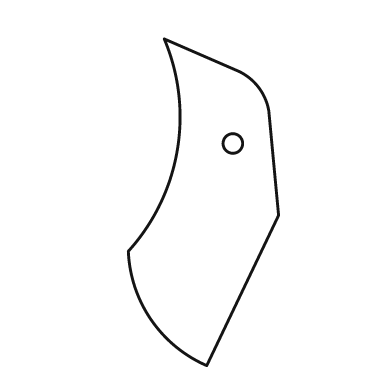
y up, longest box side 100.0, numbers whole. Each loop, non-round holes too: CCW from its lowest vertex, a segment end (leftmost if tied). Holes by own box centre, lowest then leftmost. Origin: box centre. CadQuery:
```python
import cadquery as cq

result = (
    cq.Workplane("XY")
    .moveTo(1.0, -50.0)
    .lineTo(23.0, -4.0)
    .lineTo(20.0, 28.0)
    .threePointArc((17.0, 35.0), (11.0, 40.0))
    .lineTo(-12.0, 50.0)
    .threePointArc((-8.0, 16.0), (-23.0, -15.0))
    .threePointArc((-16.0, -36.0), (1.0, -50.0))
    .close()
    .moveTo(9.0, 18.0)
    .circle(3.0)
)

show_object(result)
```